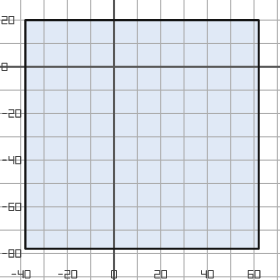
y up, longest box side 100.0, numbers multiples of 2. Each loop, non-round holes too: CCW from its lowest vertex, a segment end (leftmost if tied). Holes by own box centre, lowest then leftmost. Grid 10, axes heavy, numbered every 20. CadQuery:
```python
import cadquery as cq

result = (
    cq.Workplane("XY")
    .moveTo(-38.0, -78.0)
    .lineTo(62.0, -78.0)
    .lineTo(62.0, 20.0)
    .lineTo(-38.0, 20.0)
    .close()
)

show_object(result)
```